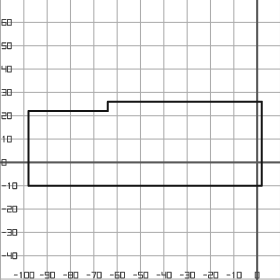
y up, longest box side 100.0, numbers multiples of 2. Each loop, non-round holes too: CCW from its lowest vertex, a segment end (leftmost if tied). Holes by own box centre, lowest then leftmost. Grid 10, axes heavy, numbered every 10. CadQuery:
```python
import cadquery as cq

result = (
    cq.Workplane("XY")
    .moveTo(-98.0, -10.0)
    .lineTo(2.0, -10.0)
    .lineTo(2.0, 26.0)
    .lineTo(-64.0, 26.0)
    .lineTo(-64.0, 22.0)
    .lineTo(-98.0, 22.0)
    .close()
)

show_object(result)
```